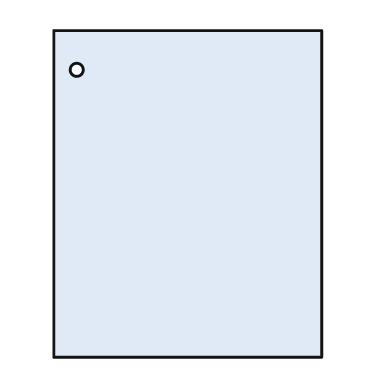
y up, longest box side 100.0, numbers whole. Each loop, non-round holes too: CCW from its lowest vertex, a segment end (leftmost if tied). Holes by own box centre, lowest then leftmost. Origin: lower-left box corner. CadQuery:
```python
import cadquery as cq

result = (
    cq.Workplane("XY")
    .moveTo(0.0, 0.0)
    .lineTo(82.0, 0.0)
    .lineTo(82.0, 100.0)
    .lineTo(0.0, 100.0)
    .close()
    .moveTo(7.0, 88.0)
    .circle(2.0)
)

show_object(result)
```